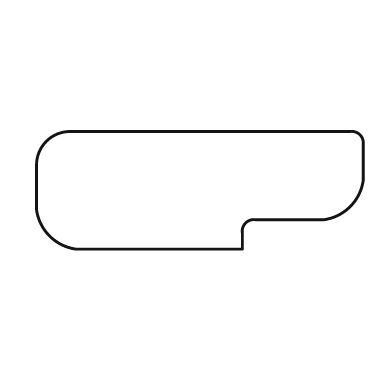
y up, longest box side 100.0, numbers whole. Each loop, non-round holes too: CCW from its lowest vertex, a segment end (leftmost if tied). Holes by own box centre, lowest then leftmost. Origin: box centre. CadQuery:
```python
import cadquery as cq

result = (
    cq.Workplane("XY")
    .moveTo(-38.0, -18.0)
    .lineTo(13.0, -18.0)
    .lineTo(13.0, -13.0)
    .threePointArc((14.0, -10.0), (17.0, -9.0))
    .lineTo(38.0, -9.0)
    .threePointArc((46.0, -5.0), (50.0, 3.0))
    .lineTo(50.0, 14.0)
    .threePointArc((49.0, 17.0), (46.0, 18.0))
    .lineTo(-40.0, 18.0)
    .threePointArc((-47.0, 15.0), (-50.0, 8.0))
    .lineTo(-50.0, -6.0)
    .threePointArc((-46.0, -14.0), (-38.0, -18.0))
    .close()
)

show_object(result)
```